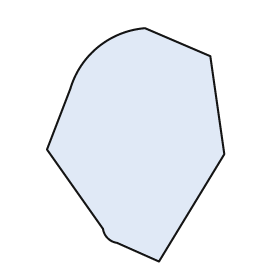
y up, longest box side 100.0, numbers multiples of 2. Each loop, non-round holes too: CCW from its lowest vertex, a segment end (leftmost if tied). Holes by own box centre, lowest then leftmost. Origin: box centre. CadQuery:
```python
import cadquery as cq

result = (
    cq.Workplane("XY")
    .moveTo(10.0, -50.0)
    .lineTo(38.0, -4.0)
    .lineTo(32.0, 38.0)
    .lineTo(4.0, 50.0)
    .threePointArc((-16.0, 42.0), (-28.0, 24.0))
    .lineTo(-38.0, -2.0)
    .lineTo(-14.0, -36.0)
    .threePointArc((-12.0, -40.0), (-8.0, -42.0))
    .close()
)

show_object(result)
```